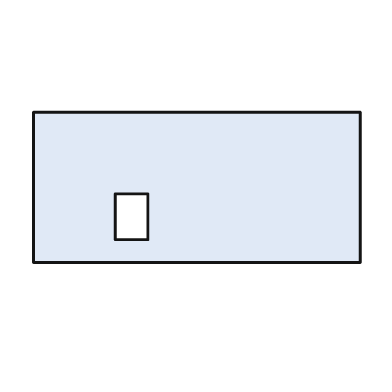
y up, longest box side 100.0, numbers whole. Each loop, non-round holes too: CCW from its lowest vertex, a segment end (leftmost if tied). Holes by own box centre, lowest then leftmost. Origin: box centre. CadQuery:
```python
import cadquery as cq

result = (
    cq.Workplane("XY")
    .moveTo(-50.0, -23.0)
    .lineTo(50.0, -23.0)
    .lineTo(50.0, 23.0)
    .lineTo(-50.0, 23.0)
    .close()
    .moveTo(-25.0, -16.0)
    .lineTo(-15.0, -16.0)
    .lineTo(-15.0, -2.0)
    .lineTo(-25.0, -2.0)
    .close()
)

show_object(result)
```